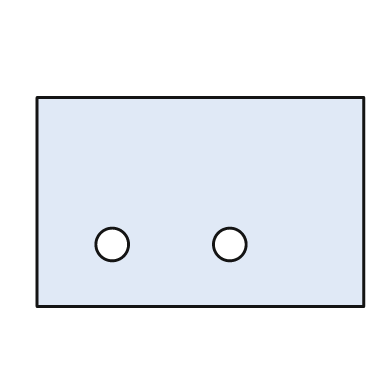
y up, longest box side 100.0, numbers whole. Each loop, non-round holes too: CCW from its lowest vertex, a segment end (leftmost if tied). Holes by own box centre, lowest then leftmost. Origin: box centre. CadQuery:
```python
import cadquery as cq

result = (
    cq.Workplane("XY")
    .moveTo(-50.0, -32.0)
    .lineTo(50.0, -32.0)
    .lineTo(50.0, 32.0)
    .lineTo(-50.0, 32.0)
    .close()
    .moveTo(-27.0, -13.0)
    .circle(5.0)
    .moveTo(9.0, -13.0)
    .circle(5.0)
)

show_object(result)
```